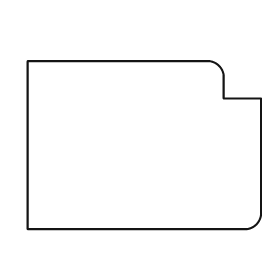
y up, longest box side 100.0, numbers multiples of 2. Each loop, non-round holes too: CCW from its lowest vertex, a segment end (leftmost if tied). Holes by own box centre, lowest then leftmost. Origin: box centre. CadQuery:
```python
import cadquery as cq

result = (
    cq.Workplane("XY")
    .moveTo(-50.0, -36.0)
    .lineTo(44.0, -36.0)
    .threePointArc((48.0, -34.0), (50.0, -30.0))
    .lineTo(50.0, 20.0)
    .lineTo(34.0, 20.0)
    .lineTo(34.0, 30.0)
    .threePointArc((32.0, 34.0), (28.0, 36.0))
    .lineTo(-50.0, 36.0)
    .close()
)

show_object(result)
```